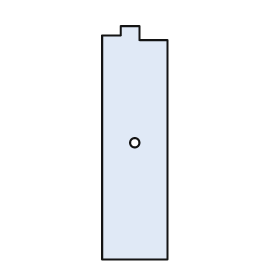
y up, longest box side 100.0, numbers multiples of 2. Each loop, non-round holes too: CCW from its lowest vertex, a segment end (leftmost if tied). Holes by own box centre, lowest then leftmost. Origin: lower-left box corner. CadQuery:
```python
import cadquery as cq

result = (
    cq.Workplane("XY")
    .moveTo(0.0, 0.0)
    .lineTo(28.0, 0.0)
    .lineTo(28.0, 94.0)
    .lineTo(16.0, 94.0)
    .lineTo(16.0, 100.0)
    .lineTo(8.0, 100.0)
    .lineTo(8.0, 96.0)
    .lineTo(0.0, 96.0)
    .close()
    .moveTo(14.0, 50.0)
    .circle(2.0)
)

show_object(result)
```